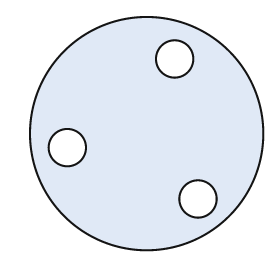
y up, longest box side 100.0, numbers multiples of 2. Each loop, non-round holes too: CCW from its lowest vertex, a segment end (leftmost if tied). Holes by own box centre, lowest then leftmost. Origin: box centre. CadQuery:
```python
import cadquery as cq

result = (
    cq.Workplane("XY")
    .moveTo(0.0, 0.0)
    .circle(50.0)
    .moveTo(22.0, -28.0)
    .circle(8.0)
    .moveTo(-34.0, -6.0)
    .circle(8.0)
    .moveTo(12.0, 32.0)
    .circle(8.0)
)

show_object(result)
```